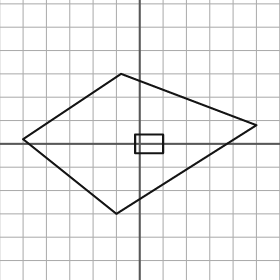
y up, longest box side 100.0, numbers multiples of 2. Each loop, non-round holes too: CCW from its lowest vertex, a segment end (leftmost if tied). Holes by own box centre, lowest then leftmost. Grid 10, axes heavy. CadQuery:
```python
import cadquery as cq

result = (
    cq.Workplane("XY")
    .moveTo(-10.0, -30.0)
    .lineTo(50.0, 8.0)
    .lineTo(-8.0, 30.0)
    .lineTo(-50.0, 2.0)
    .close()
    .moveTo(-2.0, -4.0)
    .lineTo(10.0, -4.0)
    .lineTo(10.0, 4.0)
    .lineTo(-2.0, 4.0)
    .close()
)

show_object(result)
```